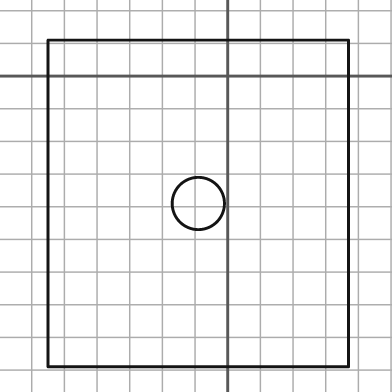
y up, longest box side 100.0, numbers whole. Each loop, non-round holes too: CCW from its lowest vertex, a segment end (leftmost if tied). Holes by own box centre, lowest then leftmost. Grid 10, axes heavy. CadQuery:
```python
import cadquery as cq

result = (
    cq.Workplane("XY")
    .moveTo(-55.0, -89.0)
    .lineTo(37.0, -89.0)
    .lineTo(37.0, 11.0)
    .lineTo(-55.0, 11.0)
    .close()
    .moveTo(-9.0, -39.0)
    .circle(8.0)
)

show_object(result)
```